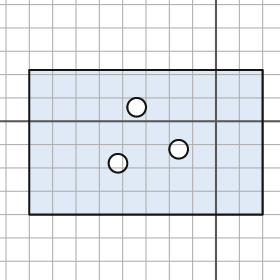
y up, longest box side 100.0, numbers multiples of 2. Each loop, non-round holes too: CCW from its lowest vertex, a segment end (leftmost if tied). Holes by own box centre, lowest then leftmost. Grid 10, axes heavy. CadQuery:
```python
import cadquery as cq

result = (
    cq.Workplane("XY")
    .moveTo(-80.0, -40.0)
    .lineTo(20.0, -40.0)
    .lineTo(20.0, 22.0)
    .lineTo(-80.0, 22.0)
    .close()
    .moveTo(-42.0, -18.0)
    .circle(4.0)
    .moveTo(-16.0, -12.0)
    .circle(4.0)
    .moveTo(-34.0, 6.0)
    .circle(4.0)
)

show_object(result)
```